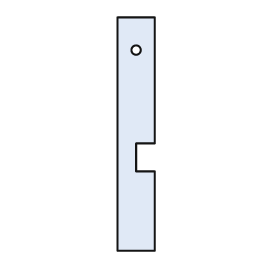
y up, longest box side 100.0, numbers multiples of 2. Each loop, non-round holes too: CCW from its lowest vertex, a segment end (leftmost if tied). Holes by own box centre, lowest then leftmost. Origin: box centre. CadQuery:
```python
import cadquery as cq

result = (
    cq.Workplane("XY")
    .moveTo(-8.0, -50.0)
    .lineTo(8.0, -50.0)
    .lineTo(8.0, -16.0)
    .lineTo(0.0, -16.0)
    .lineTo(0.0, -4.0)
    .lineTo(8.0, -4.0)
    .lineTo(8.0, 50.0)
    .lineTo(-8.0, 50.0)
    .close()
    .moveTo(0.0, 36.0)
    .circle(2.0)
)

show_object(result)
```